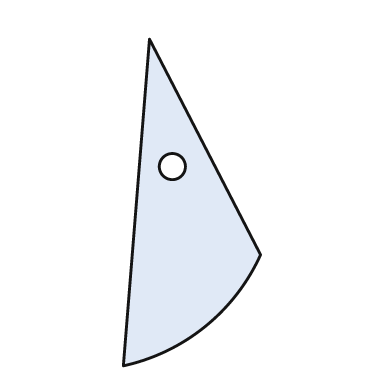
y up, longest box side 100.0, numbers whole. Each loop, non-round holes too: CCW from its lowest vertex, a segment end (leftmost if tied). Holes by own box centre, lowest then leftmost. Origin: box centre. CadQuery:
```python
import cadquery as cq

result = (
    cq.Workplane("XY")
    .moveTo(-21.0, -50.0)
    .threePointArc((4.0, -38.0), (21.0, -16.0))
    .lineTo(-13.0, 50.0)
    .close()
    .moveTo(-6.0, 11.0)
    .circle(4.0)
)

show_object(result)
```